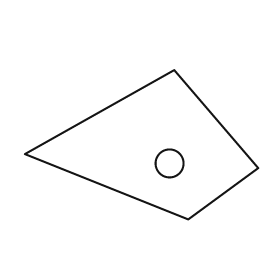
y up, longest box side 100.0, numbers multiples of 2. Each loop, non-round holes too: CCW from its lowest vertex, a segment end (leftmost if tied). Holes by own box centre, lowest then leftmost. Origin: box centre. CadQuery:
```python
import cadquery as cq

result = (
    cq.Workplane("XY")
    .moveTo(20.0, -32.0)
    .lineTo(50.0, -10.0)
    .lineTo(14.0, 32.0)
    .lineTo(-50.0, -4.0)
    .close()
    .moveTo(12.0, -8.0)
    .circle(6.0)
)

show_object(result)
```